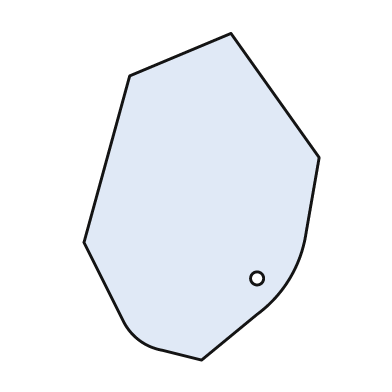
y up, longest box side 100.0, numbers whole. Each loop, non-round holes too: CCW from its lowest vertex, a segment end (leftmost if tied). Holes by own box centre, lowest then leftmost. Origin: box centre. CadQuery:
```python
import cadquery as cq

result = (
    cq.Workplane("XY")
    .moveTo(0.0, -50.0)
    .lineTo(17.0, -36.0)
    .threePointArc((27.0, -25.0), (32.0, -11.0))
    .lineTo(36.0, 12.0)
    .lineTo(9.0, 50.0)
    .lineTo(-22.0, 37.0)
    .lineTo(-36.0, -14.0)
    .lineTo(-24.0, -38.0)
    .threePointArc((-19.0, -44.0), (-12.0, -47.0))
    .close()
    .moveTo(17.0, -25.0)
    .circle(2.0)
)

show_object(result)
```